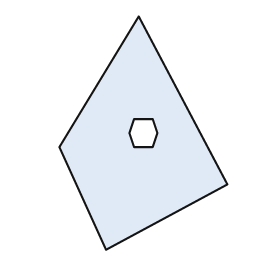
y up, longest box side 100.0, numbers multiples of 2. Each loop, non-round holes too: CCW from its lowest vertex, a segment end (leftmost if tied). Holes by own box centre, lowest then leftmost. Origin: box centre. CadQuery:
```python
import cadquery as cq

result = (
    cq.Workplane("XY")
    .moveTo(-16.0, -50.0)
    .lineTo(36.0, -22.0)
    .lineTo(-2.0, 50.0)
    .lineTo(-36.0, -6.0)
    .close()
    .moveTo(-4.0, -6.0)
    .lineTo(4.0, -6.0)
    .lineTo(6.0, 0.0)
    .lineTo(4.0, 6.0)
    .lineTo(-4.0, 6.0)
    .lineTo(-6.0, 0.0)
    .close()
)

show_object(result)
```